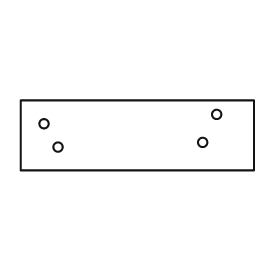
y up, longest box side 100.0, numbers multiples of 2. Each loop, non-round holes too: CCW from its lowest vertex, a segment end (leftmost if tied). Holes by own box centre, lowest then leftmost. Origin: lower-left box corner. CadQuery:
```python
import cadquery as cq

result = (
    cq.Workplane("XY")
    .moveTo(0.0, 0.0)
    .lineTo(100.0, 0.0)
    .lineTo(100.0, 30.0)
    .lineTo(0.0, 30.0)
    .close()
    .moveTo(16.0, 10.0)
    .circle(2.0)
    .moveTo(78.0, 12.0)
    .circle(2.0)
    .moveTo(10.0, 20.0)
    .circle(2.0)
    .moveTo(84.0, 24.0)
    .circle(2.0)
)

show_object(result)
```